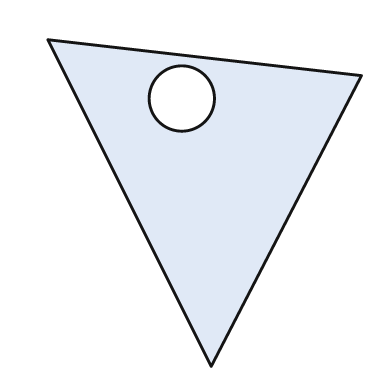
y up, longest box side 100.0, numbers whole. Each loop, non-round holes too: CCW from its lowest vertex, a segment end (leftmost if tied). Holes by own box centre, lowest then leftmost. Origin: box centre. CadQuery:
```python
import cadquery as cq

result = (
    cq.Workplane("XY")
    .moveTo(2.0, -50.0)
    .lineTo(48.0, 39.0)
    .lineTo(-48.0, 50.0)
    .close()
    .moveTo(-7.0, 32.0)
    .circle(10.0)
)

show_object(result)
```